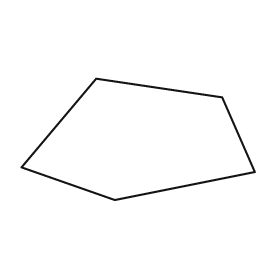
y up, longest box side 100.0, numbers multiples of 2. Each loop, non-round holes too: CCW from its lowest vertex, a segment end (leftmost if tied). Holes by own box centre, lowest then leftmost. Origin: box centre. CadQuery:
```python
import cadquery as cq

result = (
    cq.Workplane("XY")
    .moveTo(-10.0, -26.0)
    .lineTo(50.0, -14.0)
    .lineTo(36.0, 18.0)
    .lineTo(-18.0, 26.0)
    .lineTo(-50.0, -12.0)
    .close()
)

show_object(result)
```